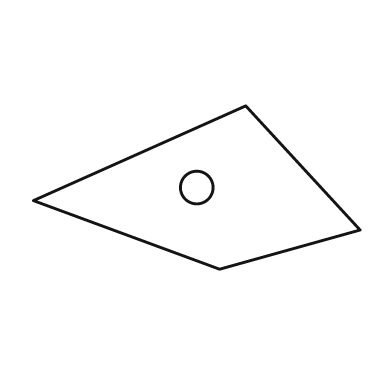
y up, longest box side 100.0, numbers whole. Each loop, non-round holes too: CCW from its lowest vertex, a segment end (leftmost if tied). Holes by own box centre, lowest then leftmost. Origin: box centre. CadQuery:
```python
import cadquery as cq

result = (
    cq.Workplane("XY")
    .moveTo(7.0, -25.0)
    .lineTo(50.0, -13.0)
    .lineTo(15.0, 25.0)
    .lineTo(-50.0, -4.0)
    .close()
    .moveTo(0.0, 0.0)
    .circle(5.0)
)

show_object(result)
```